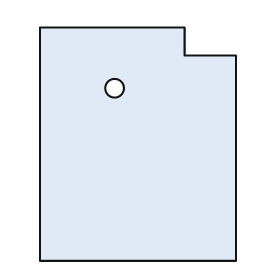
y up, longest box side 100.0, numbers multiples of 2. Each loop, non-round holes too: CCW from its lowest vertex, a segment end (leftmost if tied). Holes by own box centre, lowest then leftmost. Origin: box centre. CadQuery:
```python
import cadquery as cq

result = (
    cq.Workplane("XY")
    .moveTo(-42.0, -50.0)
    .lineTo(42.0, -50.0)
    .lineTo(42.0, 38.0)
    .lineTo(20.0, 38.0)
    .lineTo(20.0, 50.0)
    .lineTo(-42.0, 50.0)
    .close()
    .moveTo(-10.0, 24.0)
    .circle(4.0)
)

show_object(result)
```